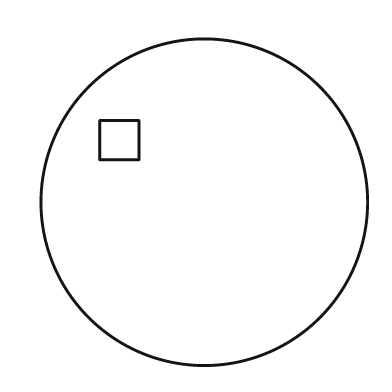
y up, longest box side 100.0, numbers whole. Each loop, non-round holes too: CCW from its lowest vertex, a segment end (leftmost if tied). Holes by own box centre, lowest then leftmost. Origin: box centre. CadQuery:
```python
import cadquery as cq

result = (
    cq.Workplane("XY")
    .moveTo(0.0, 0.0)
    .circle(50.0)
    .moveTo(-32.0, 13.0)
    .lineTo(-20.0, 13.0)
    .lineTo(-20.0, 25.0)
    .lineTo(-32.0, 25.0)
    .close()
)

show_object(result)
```